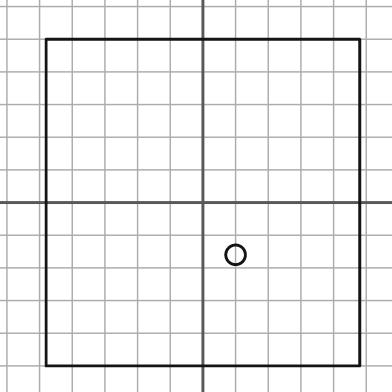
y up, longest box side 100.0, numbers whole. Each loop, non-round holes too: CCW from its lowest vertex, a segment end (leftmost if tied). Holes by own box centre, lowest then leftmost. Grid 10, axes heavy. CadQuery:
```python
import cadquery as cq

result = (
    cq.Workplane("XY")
    .moveTo(-48.0, -50.0)
    .lineTo(48.0, -50.0)
    .lineTo(48.0, 50.0)
    .lineTo(-48.0, 50.0)
    .close()
    .moveTo(10.0, -16.0)
    .circle(3.0)
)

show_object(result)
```